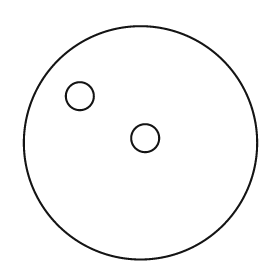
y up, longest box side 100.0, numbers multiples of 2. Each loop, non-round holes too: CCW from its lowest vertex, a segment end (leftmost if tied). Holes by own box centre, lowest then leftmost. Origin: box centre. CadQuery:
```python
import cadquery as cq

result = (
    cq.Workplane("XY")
    .moveTo(0.0, 0.0)
    .circle(50.0)
    .moveTo(2.0, 2.0)
    .circle(6.0)
    .moveTo(-26.0, 20.0)
    .circle(6.0)
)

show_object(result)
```